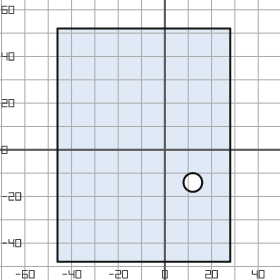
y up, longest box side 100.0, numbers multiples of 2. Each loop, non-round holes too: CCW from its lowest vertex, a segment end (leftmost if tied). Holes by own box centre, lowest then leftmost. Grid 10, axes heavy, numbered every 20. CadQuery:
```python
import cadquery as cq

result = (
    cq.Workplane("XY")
    .moveTo(-46.0, -48.0)
    .lineTo(28.0, -48.0)
    .lineTo(28.0, 52.0)
    .lineTo(-46.0, 52.0)
    .close()
    .moveTo(12.0, -14.0)
    .circle(4.0)
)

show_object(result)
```